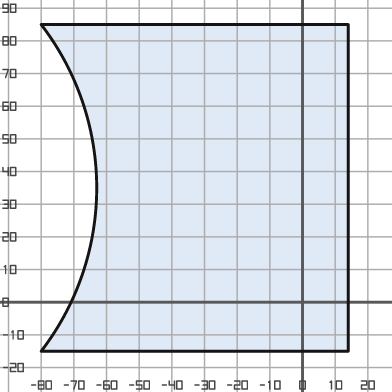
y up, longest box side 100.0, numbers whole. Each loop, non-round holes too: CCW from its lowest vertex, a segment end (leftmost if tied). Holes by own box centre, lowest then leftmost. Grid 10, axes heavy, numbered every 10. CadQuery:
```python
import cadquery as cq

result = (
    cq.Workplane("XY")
    .moveTo(-80.0, -15.0)
    .lineTo(14.0, -15.0)
    .lineTo(14.0, 85.0)
    .lineTo(-80.0, 85.0)
    .threePointArc((-63.0, 35.0), (-80.0, -15.0))
    .close()
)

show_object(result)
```